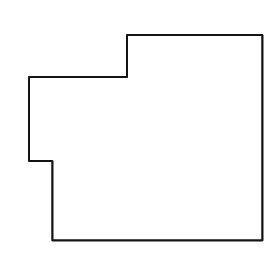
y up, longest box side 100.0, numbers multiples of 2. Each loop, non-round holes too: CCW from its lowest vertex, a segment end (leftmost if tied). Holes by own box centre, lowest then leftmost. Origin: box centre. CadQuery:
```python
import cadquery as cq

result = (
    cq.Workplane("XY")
    .moveTo(-40.0, -44.0)
    .lineTo(50.0, -44.0)
    .lineTo(50.0, 44.0)
    .lineTo(-8.0, 44.0)
    .lineTo(-8.0, 26.0)
    .lineTo(-50.0, 26.0)
    .lineTo(-50.0, -10.0)
    .lineTo(-40.0, -10.0)
    .close()
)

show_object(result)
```